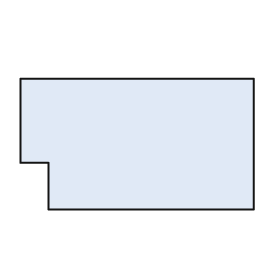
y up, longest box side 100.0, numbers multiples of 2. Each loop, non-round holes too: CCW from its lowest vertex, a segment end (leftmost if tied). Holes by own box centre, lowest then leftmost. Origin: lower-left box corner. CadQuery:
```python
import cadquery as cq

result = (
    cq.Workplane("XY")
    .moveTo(12.0, 0.0)
    .lineTo(100.0, 0.0)
    .lineTo(100.0, 56.0)
    .lineTo(0.0, 56.0)
    .lineTo(0.0, 20.0)
    .lineTo(12.0, 20.0)
    .close()
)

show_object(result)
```